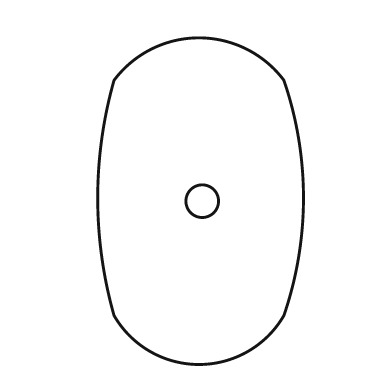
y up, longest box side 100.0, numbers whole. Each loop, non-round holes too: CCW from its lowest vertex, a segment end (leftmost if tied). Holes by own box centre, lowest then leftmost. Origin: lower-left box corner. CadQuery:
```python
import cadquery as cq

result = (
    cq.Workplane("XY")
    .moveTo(5.0, 15.0)
    .threePointArc((31.0, 0.0), (57.0, 15.0))
    .threePointArc((63.0, 51.0), (57.0, 87.0))
    .threePointArc((31.0, 100.0), (5.0, 87.0))
    .threePointArc((0.0, 51.0), (5.0, 15.0))
    .close()
    .moveTo(32.0, 50.0)
    .circle(5.0)
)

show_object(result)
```